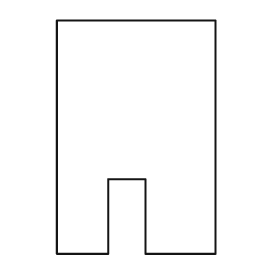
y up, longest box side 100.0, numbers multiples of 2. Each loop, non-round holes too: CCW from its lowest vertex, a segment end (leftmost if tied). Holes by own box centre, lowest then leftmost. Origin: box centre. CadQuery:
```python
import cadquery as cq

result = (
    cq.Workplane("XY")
    .moveTo(-34.0, -50.0)
    .lineTo(-12.0, -50.0)
    .lineTo(-12.0, -18.0)
    .lineTo(4.0, -18.0)
    .lineTo(4.0, -50.0)
    .lineTo(34.0, -50.0)
    .lineTo(34.0, 50.0)
    .lineTo(-34.0, 50.0)
    .close()
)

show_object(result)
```